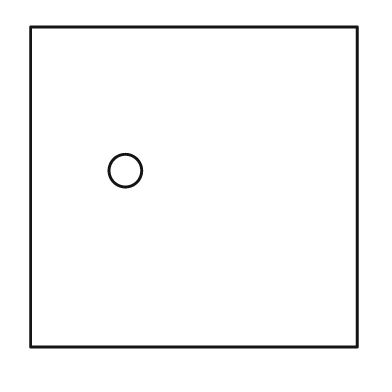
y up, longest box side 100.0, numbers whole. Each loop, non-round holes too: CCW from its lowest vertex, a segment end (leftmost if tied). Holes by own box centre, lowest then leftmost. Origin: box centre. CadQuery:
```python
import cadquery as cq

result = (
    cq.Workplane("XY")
    .moveTo(-50.0, -49.0)
    .lineTo(50.0, -49.0)
    .lineTo(50.0, 49.0)
    .lineTo(-50.0, 49.0)
    .close()
    .moveTo(-21.0, 5.0)
    .circle(5.0)
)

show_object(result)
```